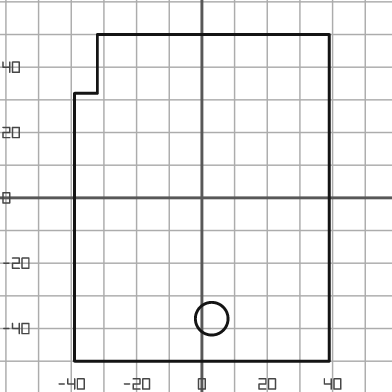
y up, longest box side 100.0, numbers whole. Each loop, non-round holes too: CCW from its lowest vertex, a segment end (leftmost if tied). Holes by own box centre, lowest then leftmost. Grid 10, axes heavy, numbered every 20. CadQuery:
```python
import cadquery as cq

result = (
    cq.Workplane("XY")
    .moveTo(-39.0, -50.0)
    .lineTo(39.0, -50.0)
    .lineTo(39.0, 50.0)
    .lineTo(-32.0, 50.0)
    .lineTo(-32.0, 32.0)
    .lineTo(-39.0, 32.0)
    .close()
    .moveTo(3.0, -37.0)
    .circle(5.0)
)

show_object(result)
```